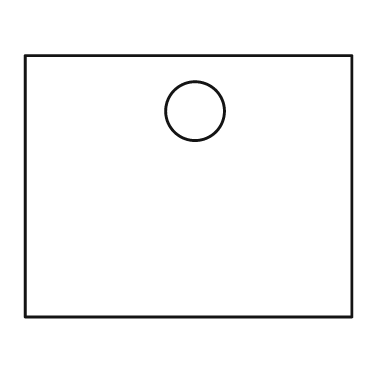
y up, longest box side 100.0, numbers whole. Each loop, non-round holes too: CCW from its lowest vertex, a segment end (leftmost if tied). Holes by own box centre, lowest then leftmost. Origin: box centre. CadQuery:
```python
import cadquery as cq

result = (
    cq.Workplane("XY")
    .moveTo(-50.0, -40.0)
    .lineTo(50.0, -40.0)
    .lineTo(50.0, 40.0)
    .lineTo(-50.0, 40.0)
    .close()
    .moveTo(2.0, 23.0)
    .circle(9.0)
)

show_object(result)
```